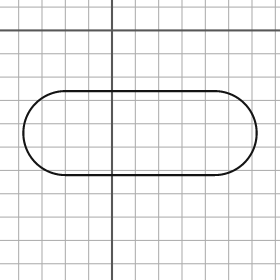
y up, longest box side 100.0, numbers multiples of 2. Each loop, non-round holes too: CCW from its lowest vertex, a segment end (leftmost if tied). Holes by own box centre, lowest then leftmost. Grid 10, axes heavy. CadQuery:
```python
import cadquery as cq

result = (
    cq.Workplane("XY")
    .moveTo(-20.0, -62.0)
    .lineTo(44.0, -62.0)
    .threePointArc((62.0, -44.0), (44.0, -26.0))
    .lineTo(-20.0, -26.0)
    .threePointArc((-38.0, -44.0), (-20.0, -62.0))
    .close()
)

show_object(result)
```